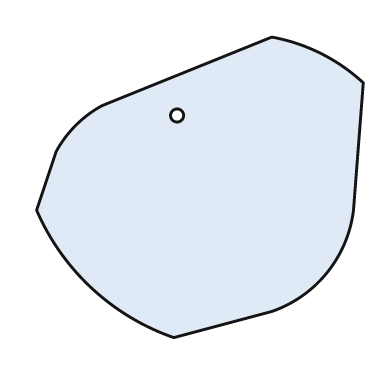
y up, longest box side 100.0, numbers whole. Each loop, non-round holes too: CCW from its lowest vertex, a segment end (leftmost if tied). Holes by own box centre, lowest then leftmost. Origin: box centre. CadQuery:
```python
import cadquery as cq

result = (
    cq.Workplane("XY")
    .moveTo(-8.0, -46.0)
    .lineTo(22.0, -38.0)
    .threePointArc((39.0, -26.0), (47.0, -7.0))
    .lineTo(50.0, 32.0)
    .threePointArc((37.0, 41.0), (22.0, 46.0))
    .lineTo(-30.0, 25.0)
    .threePointArc((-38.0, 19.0), (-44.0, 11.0))
    .lineTo(-50.0, -7.0)
    .threePointArc((-33.0, -31.0), (-8.0, -46.0))
    .close()
    .moveTo(-7.0, 22.0)
    .circle(2.0)
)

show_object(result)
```